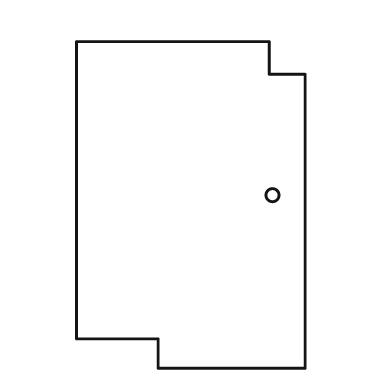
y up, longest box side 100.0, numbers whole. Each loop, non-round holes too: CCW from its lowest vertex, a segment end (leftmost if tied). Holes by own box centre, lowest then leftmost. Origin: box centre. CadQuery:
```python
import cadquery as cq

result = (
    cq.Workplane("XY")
    .moveTo(-10.0, -50.0)
    .lineTo(35.0, -50.0)
    .lineTo(35.0, 40.0)
    .lineTo(24.0, 40.0)
    .lineTo(24.0, 50.0)
    .lineTo(-35.0, 50.0)
    .lineTo(-35.0, -41.0)
    .lineTo(-10.0, -41.0)
    .close()
    .moveTo(25.0, 3.0)
    .circle(2.0)
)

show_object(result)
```